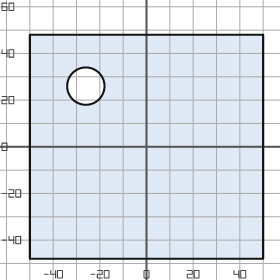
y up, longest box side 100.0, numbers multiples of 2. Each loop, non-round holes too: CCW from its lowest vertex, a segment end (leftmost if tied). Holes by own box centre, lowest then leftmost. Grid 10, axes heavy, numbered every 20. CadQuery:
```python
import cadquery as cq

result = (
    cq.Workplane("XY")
    .moveTo(-50.0, -48.0)
    .lineTo(50.0, -48.0)
    .lineTo(50.0, 48.0)
    .lineTo(-50.0, 48.0)
    .close()
    .moveTo(-26.0, 26.0)
    .circle(8.0)
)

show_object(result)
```